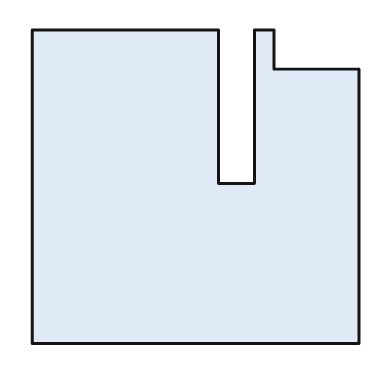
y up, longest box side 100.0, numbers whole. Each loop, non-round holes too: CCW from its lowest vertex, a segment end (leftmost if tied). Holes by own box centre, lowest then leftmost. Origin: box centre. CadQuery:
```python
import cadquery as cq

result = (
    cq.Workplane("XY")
    .moveTo(-50.0, -48.0)
    .lineTo(50.0, -48.0)
    .lineTo(50.0, 36.0)
    .lineTo(24.0, 36.0)
    .lineTo(24.0, 48.0)
    .lineTo(18.0, 48.0)
    .lineTo(18.0, 1.0)
    .lineTo(7.0, 1.0)
    .lineTo(7.0, 48.0)
    .lineTo(-50.0, 48.0)
    .close()
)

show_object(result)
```